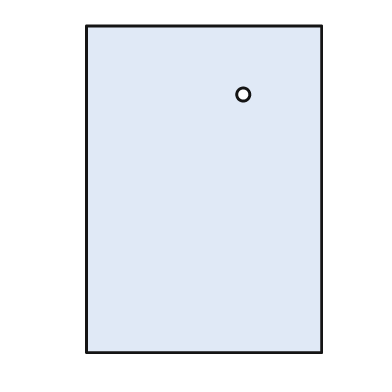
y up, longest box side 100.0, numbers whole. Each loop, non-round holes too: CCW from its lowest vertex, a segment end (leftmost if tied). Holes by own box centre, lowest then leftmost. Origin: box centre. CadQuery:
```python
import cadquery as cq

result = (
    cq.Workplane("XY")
    .moveTo(-36.0, -50.0)
    .lineTo(36.0, -50.0)
    .lineTo(36.0, 50.0)
    .lineTo(-36.0, 50.0)
    .close()
    .moveTo(12.0, 29.0)
    .circle(2.0)
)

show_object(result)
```